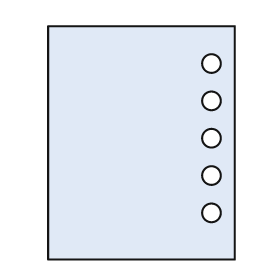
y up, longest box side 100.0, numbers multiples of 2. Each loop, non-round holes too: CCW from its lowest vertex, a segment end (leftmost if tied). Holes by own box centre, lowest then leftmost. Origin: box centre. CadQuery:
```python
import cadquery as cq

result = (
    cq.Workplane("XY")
    .moveTo(-40.0, -50.0)
    .lineTo(40.0, -50.0)
    .lineTo(40.0, 50.0)
    .lineTo(-40.0, 50.0)
    .close()
    .moveTo(30.0, -30.0)
    .circle(4.0)
    .moveTo(30.0, -14.0)
    .circle(4.0)
    .moveTo(30.0, 2.0)
    .circle(4.0)
    .moveTo(30.0, 18.0)
    .circle(4.0)
    .moveTo(30.0, 34.0)
    .circle(4.0)
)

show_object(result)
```